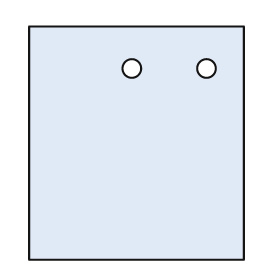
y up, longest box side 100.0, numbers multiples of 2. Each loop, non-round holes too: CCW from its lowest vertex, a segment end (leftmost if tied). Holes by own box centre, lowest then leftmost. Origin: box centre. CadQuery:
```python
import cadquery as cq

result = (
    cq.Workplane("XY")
    .moveTo(-46.0, -50.0)
    .lineTo(46.0, -50.0)
    .lineTo(46.0, 50.0)
    .lineTo(-46.0, 50.0)
    .close()
    .moveTo(-2.0, 32.0)
    .circle(4.0)
    .moveTo(30.0, 32.0)
    .circle(4.0)
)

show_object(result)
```